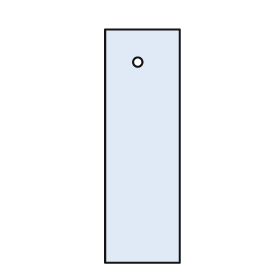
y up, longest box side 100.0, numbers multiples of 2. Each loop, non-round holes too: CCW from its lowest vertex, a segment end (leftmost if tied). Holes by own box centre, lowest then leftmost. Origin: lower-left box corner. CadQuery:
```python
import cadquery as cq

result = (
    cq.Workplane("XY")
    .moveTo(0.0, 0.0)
    .lineTo(32.0, 0.0)
    .lineTo(32.0, 100.0)
    .lineTo(0.0, 100.0)
    .close()
    .moveTo(14.0, 86.0)
    .circle(2.0)
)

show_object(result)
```